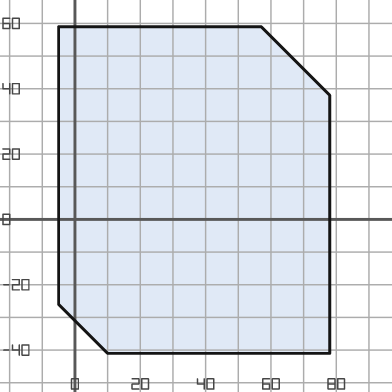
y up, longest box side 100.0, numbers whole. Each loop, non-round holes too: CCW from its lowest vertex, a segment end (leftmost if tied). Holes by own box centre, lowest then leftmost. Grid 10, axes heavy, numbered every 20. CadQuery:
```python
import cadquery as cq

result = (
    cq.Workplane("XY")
    .moveTo(10.0, -41.0)
    .lineTo(78.0, -41.0)
    .lineTo(78.0, 38.0)
    .lineTo(57.0, 59.0)
    .lineTo(-5.0, 59.0)
    .lineTo(-5.0, -26.0)
    .close()
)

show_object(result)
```